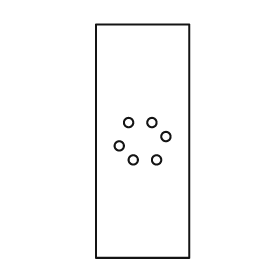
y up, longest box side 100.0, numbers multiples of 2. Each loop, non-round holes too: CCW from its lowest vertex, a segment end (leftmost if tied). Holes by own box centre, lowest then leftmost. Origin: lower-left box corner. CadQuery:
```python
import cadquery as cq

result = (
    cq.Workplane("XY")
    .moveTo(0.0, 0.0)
    .lineTo(40.0, 0.0)
    .lineTo(40.0, 100.0)
    .lineTo(0.0, 100.0)
    .close()
    .moveTo(16.0, 42.0)
    .circle(2.0)
    .moveTo(26.0, 42.0)
    .circle(2.0)
    .moveTo(10.0, 48.0)
    .circle(2.0)
    .moveTo(30.0, 52.0)
    .circle(2.0)
    .moveTo(14.0, 58.0)
    .circle(2.0)
    .moveTo(24.0, 58.0)
    .circle(2.0)
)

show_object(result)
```